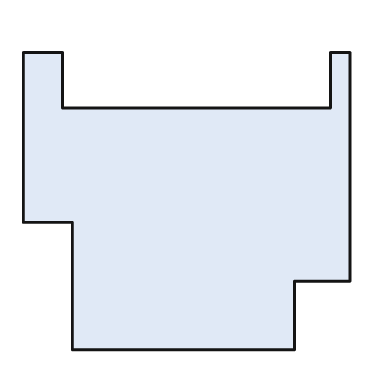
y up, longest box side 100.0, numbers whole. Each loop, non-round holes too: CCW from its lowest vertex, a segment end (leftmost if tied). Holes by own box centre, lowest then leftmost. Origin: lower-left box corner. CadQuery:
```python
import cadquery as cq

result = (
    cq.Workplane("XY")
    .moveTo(15.0, 0.0)
    .lineTo(83.0, 0.0)
    .lineTo(83.0, 21.0)
    .lineTo(100.0, 21.0)
    .lineTo(100.0, 91.0)
    .lineTo(94.0, 91.0)
    .lineTo(94.0, 74.0)
    .lineTo(12.0, 74.0)
    .lineTo(12.0, 91.0)
    .lineTo(0.0, 91.0)
    .lineTo(0.0, 39.0)
    .lineTo(15.0, 39.0)
    .close()
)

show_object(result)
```